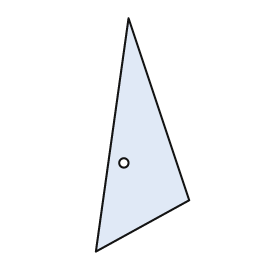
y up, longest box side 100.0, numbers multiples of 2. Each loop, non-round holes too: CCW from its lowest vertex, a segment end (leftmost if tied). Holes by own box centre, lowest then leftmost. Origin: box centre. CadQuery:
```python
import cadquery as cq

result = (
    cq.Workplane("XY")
    .moveTo(-20.0, -50.0)
    .lineTo(20.0, -28.0)
    .lineTo(-6.0, 50.0)
    .close()
    .moveTo(-8.0, -12.0)
    .circle(2.0)
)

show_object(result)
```